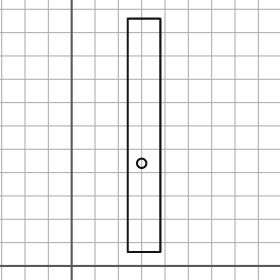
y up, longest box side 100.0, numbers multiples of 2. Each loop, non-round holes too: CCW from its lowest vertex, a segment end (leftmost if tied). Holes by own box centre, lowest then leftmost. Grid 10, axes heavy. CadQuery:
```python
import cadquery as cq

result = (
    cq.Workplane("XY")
    .moveTo(24.0, 6.0)
    .lineTo(38.0, 6.0)
    .lineTo(38.0, 106.0)
    .lineTo(24.0, 106.0)
    .close()
    .moveTo(30.0, 44.0)
    .circle(2.0)
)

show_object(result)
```